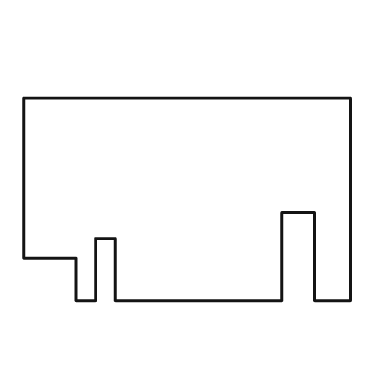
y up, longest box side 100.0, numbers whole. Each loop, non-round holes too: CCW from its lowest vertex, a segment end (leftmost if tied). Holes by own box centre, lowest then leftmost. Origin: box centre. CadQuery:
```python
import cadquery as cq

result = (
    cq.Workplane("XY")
    .moveTo(-34.0, -31.0)
    .lineTo(-28.0, -31.0)
    .lineTo(-28.0, -12.0)
    .lineTo(-22.0, -12.0)
    .lineTo(-22.0, -31.0)
    .lineTo(29.0, -31.0)
    .lineTo(29.0, -4.0)
    .lineTo(39.0, -4.0)
    .lineTo(39.0, -31.0)
    .lineTo(50.0, -31.0)
    .lineTo(50.0, 31.0)
    .lineTo(-50.0, 31.0)
    .lineTo(-50.0, -18.0)
    .lineTo(-34.0, -18.0)
    .close()
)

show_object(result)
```